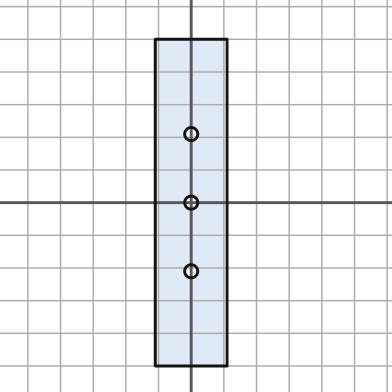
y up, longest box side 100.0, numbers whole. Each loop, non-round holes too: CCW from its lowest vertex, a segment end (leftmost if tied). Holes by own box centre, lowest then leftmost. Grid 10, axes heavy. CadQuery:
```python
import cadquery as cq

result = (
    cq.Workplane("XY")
    .moveTo(-11.0, -50.0)
    .lineTo(11.0, -50.0)
    .lineTo(11.0, 50.0)
    .lineTo(-11.0, 50.0)
    .close()
    .moveTo(0.0, -21.0)
    .circle(2.0)
    .moveTo(0.0, 0.0)
    .circle(2.0)
    .moveTo(0.0, 21.0)
    .circle(2.0)
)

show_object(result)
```